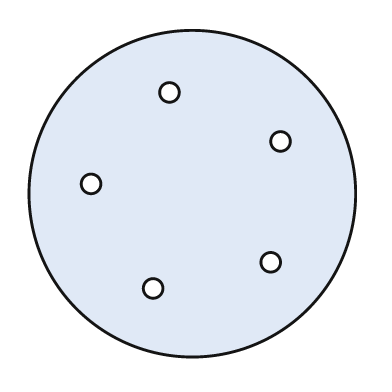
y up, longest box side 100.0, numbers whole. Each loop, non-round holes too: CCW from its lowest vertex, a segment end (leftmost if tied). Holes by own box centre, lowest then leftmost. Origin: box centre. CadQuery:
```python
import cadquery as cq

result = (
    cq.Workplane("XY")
    .moveTo(0.0, 0.0)
    .circle(50.0)
    .moveTo(-12.0, -29.0)
    .circle(3.0)
    .moveTo(24.0, -21.0)
    .circle(3.0)
    .moveTo(-31.0, 3.0)
    .circle(3.0)
    .moveTo(27.0, 16.0)
    .circle(3.0)
    .moveTo(-7.0, 31.0)
    .circle(3.0)
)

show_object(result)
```